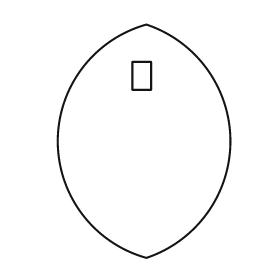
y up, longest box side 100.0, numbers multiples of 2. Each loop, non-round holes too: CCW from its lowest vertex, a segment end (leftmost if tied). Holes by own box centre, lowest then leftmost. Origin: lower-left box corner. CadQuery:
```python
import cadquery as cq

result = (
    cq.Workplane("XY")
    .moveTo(38.0, 0.0)
    .threePointArc((74.0, 50.0), (38.0, 100.0))
    .threePointArc((0.0, 50.0), (38.0, 0.0))
    .close()
    .moveTo(32.0, 72.0)
    .lineTo(40.0, 72.0)
    .lineTo(40.0, 84.0)
    .lineTo(32.0, 84.0)
    .close()
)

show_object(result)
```